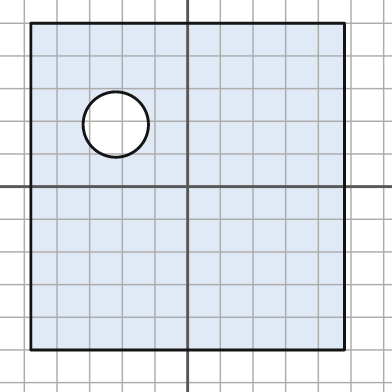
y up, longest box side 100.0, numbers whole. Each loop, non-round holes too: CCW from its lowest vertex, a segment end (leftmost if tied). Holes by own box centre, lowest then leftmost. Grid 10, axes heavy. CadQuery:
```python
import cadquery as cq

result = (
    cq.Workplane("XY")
    .moveTo(-48.0, -50.0)
    .lineTo(48.0, -50.0)
    .lineTo(48.0, 50.0)
    .lineTo(-48.0, 50.0)
    .close()
    .moveTo(-22.0, 19.0)
    .circle(10.0)
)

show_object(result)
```